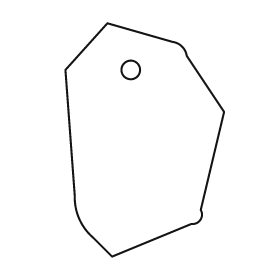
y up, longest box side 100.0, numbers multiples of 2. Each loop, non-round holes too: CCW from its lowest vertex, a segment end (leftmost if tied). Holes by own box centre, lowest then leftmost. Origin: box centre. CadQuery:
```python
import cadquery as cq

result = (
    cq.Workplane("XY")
    .moveTo(-14.0, -50.0)
    .lineTo(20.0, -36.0)
    .threePointArc((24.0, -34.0), (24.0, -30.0))
    .lineTo(34.0, 12.0)
    .lineTo(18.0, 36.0)
    .threePointArc((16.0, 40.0), (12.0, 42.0))
    .lineTo(-16.0, 50.0)
    .lineTo(-34.0, 30.0)
    .lineTo(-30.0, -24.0)
    .threePointArc((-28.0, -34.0), (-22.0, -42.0))
    .close()
    .moveTo(-6.0, 30.0)
    .circle(4.0)
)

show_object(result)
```